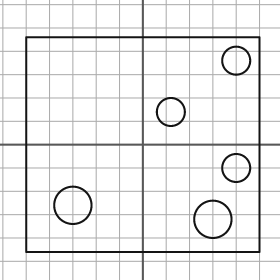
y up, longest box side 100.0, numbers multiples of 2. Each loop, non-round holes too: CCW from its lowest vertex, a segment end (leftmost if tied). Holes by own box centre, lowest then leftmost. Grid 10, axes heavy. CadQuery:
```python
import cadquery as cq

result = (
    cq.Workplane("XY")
    .moveTo(-50.0, -46.0)
    .lineTo(50.0, -46.0)
    .lineTo(50.0, 46.0)
    .lineTo(-50.0, 46.0)
    .close()
    .moveTo(30.0, -32.0)
    .circle(8.0)
    .moveTo(-30.0, -26.0)
    .circle(8.0)
    .moveTo(40.0, -10.0)
    .circle(6.0)
    .moveTo(12.0, 14.0)
    .circle(6.0)
    .moveTo(40.0, 36.0)
    .circle(6.0)
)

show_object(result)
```